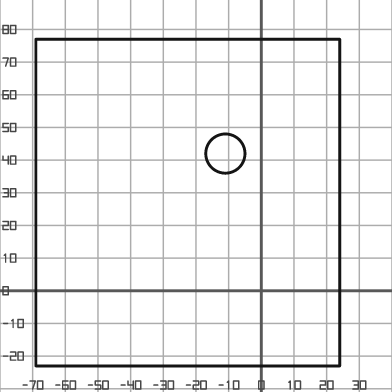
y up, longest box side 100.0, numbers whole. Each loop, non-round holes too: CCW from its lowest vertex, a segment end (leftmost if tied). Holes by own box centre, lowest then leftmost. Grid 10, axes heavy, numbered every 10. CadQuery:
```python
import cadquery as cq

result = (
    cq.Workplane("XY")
    .moveTo(-69.0, -23.0)
    .lineTo(24.0, -23.0)
    .lineTo(24.0, 77.0)
    .lineTo(-69.0, 77.0)
    .close()
    .moveTo(-11.0, 42.0)
    .circle(6.0)
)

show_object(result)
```